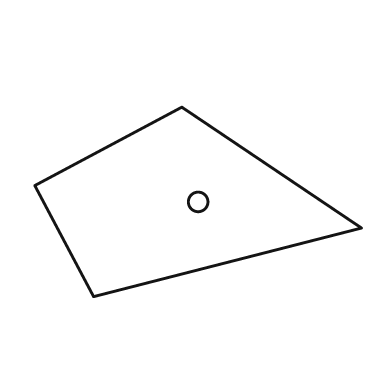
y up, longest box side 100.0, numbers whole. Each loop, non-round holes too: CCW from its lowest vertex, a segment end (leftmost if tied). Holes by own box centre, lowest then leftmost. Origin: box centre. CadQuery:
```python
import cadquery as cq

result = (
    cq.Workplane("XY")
    .moveTo(-32.0, -29.0)
    .lineTo(50.0, -8.0)
    .lineTo(-5.0, 29.0)
    .lineTo(-50.0, 5.0)
    .close()
    .moveTo(0.0, 0.0)
    .circle(3.0)
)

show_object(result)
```